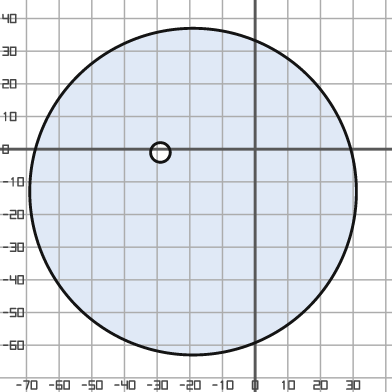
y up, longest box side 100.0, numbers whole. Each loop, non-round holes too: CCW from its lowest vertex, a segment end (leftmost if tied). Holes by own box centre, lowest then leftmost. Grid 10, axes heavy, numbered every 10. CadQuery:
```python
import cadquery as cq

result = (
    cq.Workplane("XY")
    .moveTo(-19.0, -13.0)
    .circle(50.0)
    .moveTo(-29.0, -1.0)
    .circle(3.0)
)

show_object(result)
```